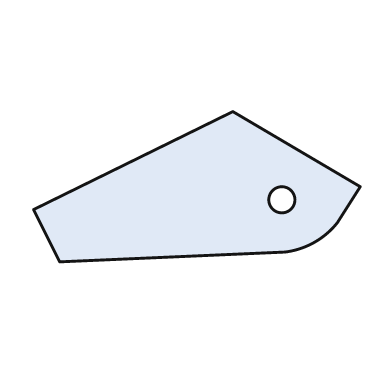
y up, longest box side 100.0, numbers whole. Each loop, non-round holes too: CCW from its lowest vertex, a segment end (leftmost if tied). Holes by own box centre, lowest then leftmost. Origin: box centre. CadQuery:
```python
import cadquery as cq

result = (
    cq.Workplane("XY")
    .moveTo(-42.0, -23.0)
    .lineTo(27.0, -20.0)
    .threePointArc((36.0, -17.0), (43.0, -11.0))
    .lineTo(50.0, 0.0)
    .lineTo(11.0, 23.0)
    .lineTo(-50.0, -7.0)
    .close()
    .moveTo(26.0, -4.0)
    .circle(4.0)
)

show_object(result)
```